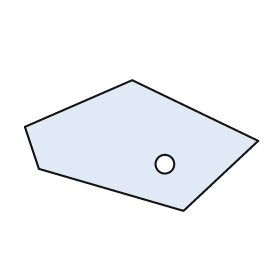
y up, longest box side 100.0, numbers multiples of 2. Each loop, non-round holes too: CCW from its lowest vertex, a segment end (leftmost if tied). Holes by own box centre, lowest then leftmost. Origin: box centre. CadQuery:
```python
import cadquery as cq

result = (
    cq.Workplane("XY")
    .moveTo(18.0, -28.0)
    .lineTo(50.0, 2.0)
    .lineTo(-4.0, 28.0)
    .lineTo(-50.0, 8.0)
    .lineTo(-44.0, -10.0)
    .close()
    .moveTo(10.0, -8.0)
    .circle(4.0)
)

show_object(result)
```